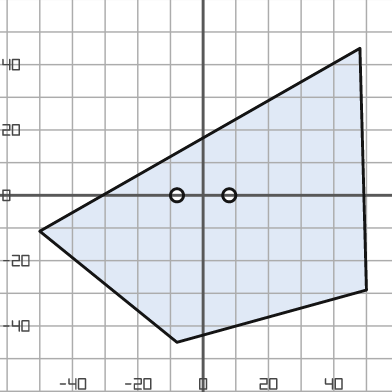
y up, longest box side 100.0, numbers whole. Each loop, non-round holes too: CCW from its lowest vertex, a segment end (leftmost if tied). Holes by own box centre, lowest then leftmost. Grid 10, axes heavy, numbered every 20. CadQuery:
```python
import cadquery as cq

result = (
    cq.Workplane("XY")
    .moveTo(-8.0, -45.0)
    .lineTo(50.0, -29.0)
    .lineTo(48.0, 45.0)
    .lineTo(-50.0, -11.0)
    .close()
    .moveTo(-8.0, 0.0)
    .circle(2.0)
    .moveTo(8.0, 0.0)
    .circle(2.0)
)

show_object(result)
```